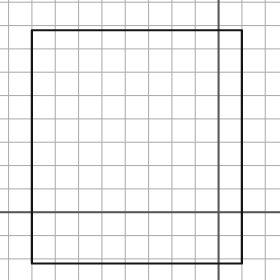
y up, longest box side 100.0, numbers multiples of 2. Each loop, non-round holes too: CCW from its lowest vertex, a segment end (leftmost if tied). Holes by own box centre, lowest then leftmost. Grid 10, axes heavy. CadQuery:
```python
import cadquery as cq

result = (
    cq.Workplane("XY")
    .moveTo(-80.0, -22.0)
    .lineTo(10.0, -22.0)
    .lineTo(10.0, 78.0)
    .lineTo(-80.0, 78.0)
    .close()
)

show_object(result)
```